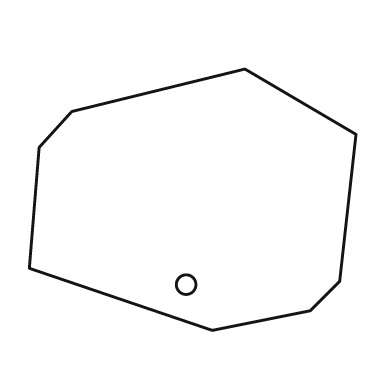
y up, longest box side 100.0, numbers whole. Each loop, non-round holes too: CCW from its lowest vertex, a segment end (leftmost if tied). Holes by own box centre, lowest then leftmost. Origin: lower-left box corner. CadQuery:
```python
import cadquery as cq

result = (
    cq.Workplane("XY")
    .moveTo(56.0, 0.0)
    .lineTo(86.0, 6.0)
    .lineTo(95.0, 15.0)
    .lineTo(100.0, 60.0)
    .lineTo(66.0, 80.0)
    .lineTo(13.0, 67.0)
    .lineTo(3.0, 56.0)
    .lineTo(0.0, 19.0)
    .close()
    .moveTo(48.0, 14.0)
    .circle(3.0)
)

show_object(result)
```